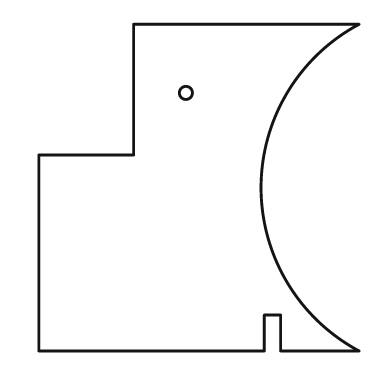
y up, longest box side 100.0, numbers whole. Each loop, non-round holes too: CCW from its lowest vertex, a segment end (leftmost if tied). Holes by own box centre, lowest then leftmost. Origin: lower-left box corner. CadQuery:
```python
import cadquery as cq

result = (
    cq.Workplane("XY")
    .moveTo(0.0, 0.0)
    .lineTo(69.0, 0.0)
    .lineTo(69.0, 11.0)
    .lineTo(74.0, 11.0)
    .lineTo(74.0, 0.0)
    .lineTo(98.0, 0.0)
    .threePointArc((68.0, 50.0), (98.0, 100.0))
    .lineTo(29.0, 100.0)
    .lineTo(29.0, 60.0)
    .lineTo(0.0, 60.0)
    .close()
    .moveTo(45.0, 79.0)
    .circle(2.0)
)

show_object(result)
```